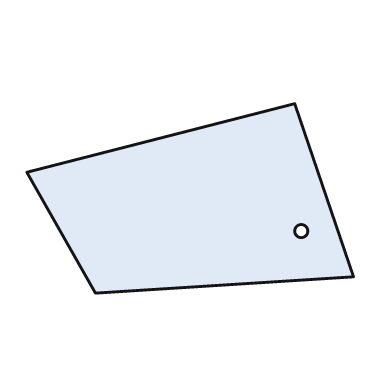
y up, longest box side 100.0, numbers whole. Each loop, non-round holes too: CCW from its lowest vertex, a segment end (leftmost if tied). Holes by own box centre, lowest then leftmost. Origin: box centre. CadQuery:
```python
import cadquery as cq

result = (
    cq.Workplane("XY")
    .moveTo(-29.0, -29.0)
    .lineTo(50.0, -24.0)
    .lineTo(32.0, 29.0)
    .lineTo(-50.0, 8.0)
    .close()
    .moveTo(34.0, -10.0)
    .circle(2.0)
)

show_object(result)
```